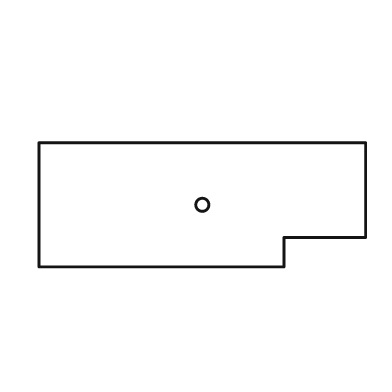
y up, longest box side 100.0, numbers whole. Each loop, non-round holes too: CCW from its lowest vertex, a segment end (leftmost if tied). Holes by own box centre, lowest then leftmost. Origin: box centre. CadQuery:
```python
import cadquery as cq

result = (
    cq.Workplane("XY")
    .moveTo(-50.0, -19.0)
    .lineTo(25.0, -19.0)
    .lineTo(25.0, -10.0)
    .lineTo(50.0, -10.0)
    .lineTo(50.0, 19.0)
    .lineTo(-50.0, 19.0)
    .close()
    .moveTo(0.0, 0.0)
    .circle(2.0)
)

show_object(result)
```